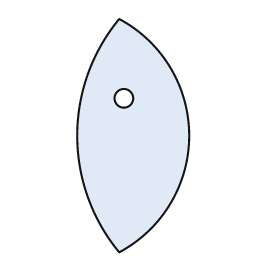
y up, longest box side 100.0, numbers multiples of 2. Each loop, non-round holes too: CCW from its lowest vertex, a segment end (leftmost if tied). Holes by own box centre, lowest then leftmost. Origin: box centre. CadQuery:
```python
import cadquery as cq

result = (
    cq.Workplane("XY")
    .moveTo(-6.0, -50.0)
    .threePointArc((24.0, 0.0), (-6.0, 50.0))
    .threePointArc((-24.0, 0.0), (-6.0, -50.0))
    .close()
    .moveTo(-4.0, 16.0)
    .circle(4.0)
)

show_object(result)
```